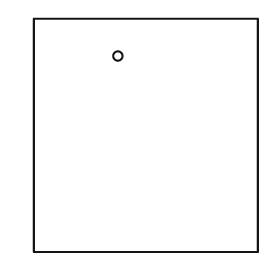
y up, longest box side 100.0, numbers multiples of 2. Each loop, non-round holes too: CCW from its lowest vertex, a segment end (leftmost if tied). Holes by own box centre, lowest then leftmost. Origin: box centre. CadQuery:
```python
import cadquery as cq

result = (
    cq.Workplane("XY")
    .moveTo(-48.0, -50.0)
    .lineTo(48.0, -50.0)
    .lineTo(48.0, 50.0)
    .lineTo(-48.0, 50.0)
    .close()
    .moveTo(-12.0, 34.0)
    .circle(2.0)
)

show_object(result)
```